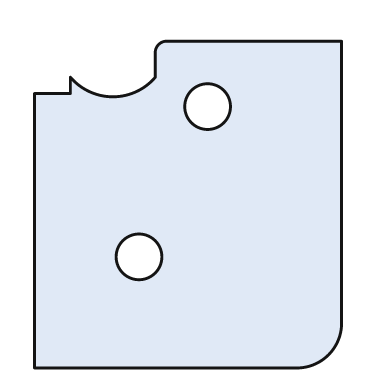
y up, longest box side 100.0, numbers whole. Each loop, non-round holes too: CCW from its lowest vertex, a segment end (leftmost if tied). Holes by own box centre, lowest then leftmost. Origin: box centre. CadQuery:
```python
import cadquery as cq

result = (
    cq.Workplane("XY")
    .moveTo(-47.0, -50.0)
    .lineTo(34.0, -50.0)
    .threePointArc((43.0, -46.0), (47.0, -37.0))
    .lineTo(47.0, 50.0)
    .lineTo(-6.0, 50.0)
    .threePointArc((-9.0, 49.0), (-10.0, 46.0))
    .lineTo(-10.0, 39.0)
    .threePointArc((-23.0, 33.0), (-36.0, 39.0))
    .lineTo(-36.0, 34.0)
    .lineTo(-47.0, 34.0)
    .close()
    .moveTo(-15.0, -16.0)
    .circle(7.0)
    .moveTo(6.0, 30.0)
    .circle(7.0)
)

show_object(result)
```